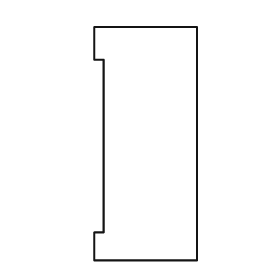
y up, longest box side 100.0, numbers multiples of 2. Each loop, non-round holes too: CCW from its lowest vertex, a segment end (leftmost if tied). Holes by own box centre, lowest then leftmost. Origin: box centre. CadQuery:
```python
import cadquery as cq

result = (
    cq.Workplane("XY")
    .moveTo(-22.0, -50.0)
    .lineTo(22.0, -50.0)
    .lineTo(22.0, 50.0)
    .lineTo(-22.0, 50.0)
    .lineTo(-22.0, 36.0)
    .lineTo(-18.0, 36.0)
    .lineTo(-18.0, -38.0)
    .lineTo(-22.0, -38.0)
    .close()
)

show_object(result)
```